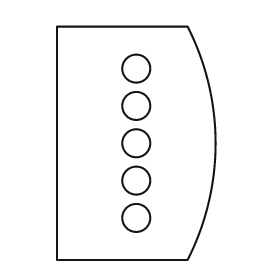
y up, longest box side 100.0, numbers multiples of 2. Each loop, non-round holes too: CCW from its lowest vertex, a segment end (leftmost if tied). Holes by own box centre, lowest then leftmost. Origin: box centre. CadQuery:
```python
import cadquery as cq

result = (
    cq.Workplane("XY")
    .moveTo(-34.0, -50.0)
    .lineTo(22.0, -50.0)
    .threePointArc((34.0, 0.0), (22.0, 50.0))
    .lineTo(-34.0, 50.0)
    .close()
    .moveTo(0.0, -32.0)
    .circle(6.0)
    .moveTo(0.0, -16.0)
    .circle(6.0)
    .moveTo(0.0, 0.0)
    .circle(6.0)
    .moveTo(0.0, 16.0)
    .circle(6.0)
    .moveTo(0.0, 32.0)
    .circle(6.0)
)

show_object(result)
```